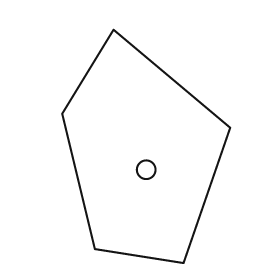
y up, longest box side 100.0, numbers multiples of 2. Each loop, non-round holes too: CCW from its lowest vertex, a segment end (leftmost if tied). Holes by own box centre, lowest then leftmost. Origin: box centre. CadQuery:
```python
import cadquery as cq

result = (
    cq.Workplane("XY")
    .moveTo(16.0, -50.0)
    .lineTo(36.0, 8.0)
    .lineTo(-14.0, 50.0)
    .lineTo(-36.0, 14.0)
    .lineTo(-22.0, -44.0)
    .close()
    .moveTo(0.0, -10.0)
    .circle(4.0)
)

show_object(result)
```